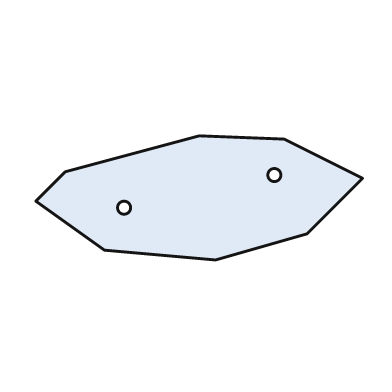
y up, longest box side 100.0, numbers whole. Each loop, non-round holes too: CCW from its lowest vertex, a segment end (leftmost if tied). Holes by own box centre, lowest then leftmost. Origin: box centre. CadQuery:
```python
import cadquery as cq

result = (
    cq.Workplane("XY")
    .moveTo(5.0, -19.0)
    .lineTo(33.0, -11.0)
    .lineTo(50.0, 6.0)
    .lineTo(26.0, 18.0)
    .lineTo(0.0, 19.0)
    .lineTo(-41.0, 8.0)
    .lineTo(-50.0, -1.0)
    .lineTo(-29.0, -16.0)
    .close()
    .moveTo(-23.0, -3.0)
    .circle(2.0)
    .moveTo(23.0, 7.0)
    .circle(2.0)
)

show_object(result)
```